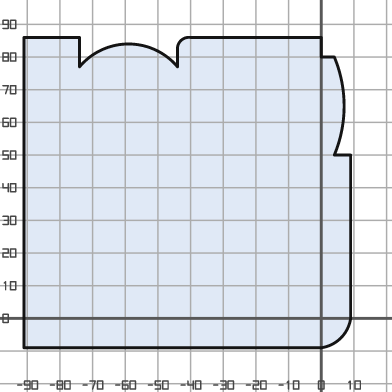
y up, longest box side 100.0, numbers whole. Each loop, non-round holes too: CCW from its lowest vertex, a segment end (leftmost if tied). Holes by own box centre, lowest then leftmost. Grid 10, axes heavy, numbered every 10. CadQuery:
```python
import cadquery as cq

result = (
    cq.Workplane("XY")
    .moveTo(-91.0, -9.0)
    .lineTo(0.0, -9.0)
    .threePointArc((6.0, -6.0), (9.0, 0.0))
    .lineTo(9.0, 50.0)
    .lineTo(4.0, 50.0)
    .threePointArc((7.0, 65.0), (4.0, 80.0))
    .lineTo(0.0, 80.0)
    .lineTo(0.0, 86.0)
    .lineTo(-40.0, 86.0)
    .threePointArc((-43.0, 85.0), (-44.0, 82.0))
    .lineTo(-44.0, 77.0)
    .threePointArc((-59.0, 84.0), (-74.0, 77.0))
    .lineTo(-74.0, 86.0)
    .lineTo(-91.0, 86.0)
    .close()
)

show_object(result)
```